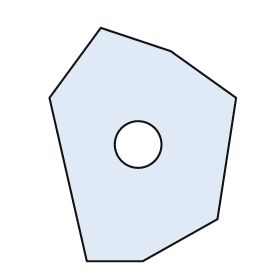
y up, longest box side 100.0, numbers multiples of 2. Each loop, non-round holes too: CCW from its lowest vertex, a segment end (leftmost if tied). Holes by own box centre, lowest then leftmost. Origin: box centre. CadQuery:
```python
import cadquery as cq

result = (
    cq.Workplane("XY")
    .moveTo(-24.0, -50.0)
    .lineTo(0.0, -50.0)
    .lineTo(32.0, -32.0)
    .lineTo(40.0, 20.0)
    .lineTo(12.0, 40.0)
    .lineTo(-18.0, 50.0)
    .lineTo(-40.0, 20.0)
    .close()
    .moveTo(-2.0, 0.0)
    .circle(10.0)
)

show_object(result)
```